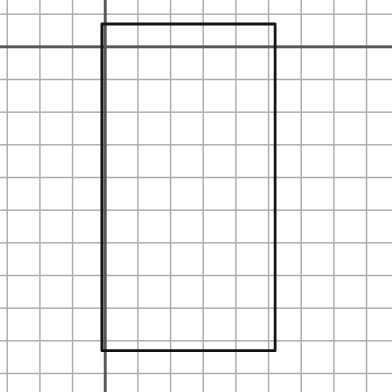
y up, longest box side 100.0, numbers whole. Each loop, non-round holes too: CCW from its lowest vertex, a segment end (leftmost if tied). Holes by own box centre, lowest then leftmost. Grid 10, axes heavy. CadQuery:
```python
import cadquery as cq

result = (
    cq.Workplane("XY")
    .moveTo(-1.0, -93.0)
    .lineTo(52.0, -93.0)
    .lineTo(52.0, 7.0)
    .lineTo(-1.0, 7.0)
    .close()
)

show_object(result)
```